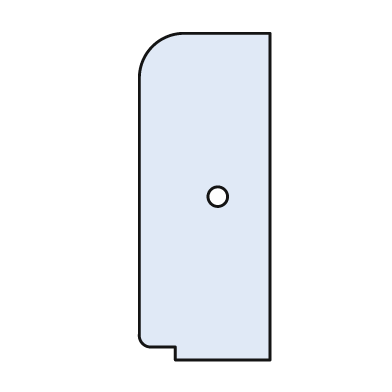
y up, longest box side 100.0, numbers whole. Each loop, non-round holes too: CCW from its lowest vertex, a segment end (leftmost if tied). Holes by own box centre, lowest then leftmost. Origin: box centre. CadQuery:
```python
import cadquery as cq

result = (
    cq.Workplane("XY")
    .moveTo(-9.0, -50.0)
    .lineTo(20.0, -50.0)
    .lineTo(20.0, 50.0)
    .lineTo(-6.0, 50.0)
    .threePointArc((-16.0, 46.0), (-20.0, 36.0))
    .lineTo(-20.0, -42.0)
    .threePointArc((-19.0, -45.0), (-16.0, -46.0))
    .lineTo(-9.0, -46.0)
    .close()
    .moveTo(4.0, 0.0)
    .circle(3.0)
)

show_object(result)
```